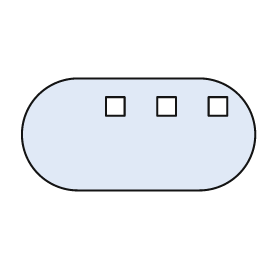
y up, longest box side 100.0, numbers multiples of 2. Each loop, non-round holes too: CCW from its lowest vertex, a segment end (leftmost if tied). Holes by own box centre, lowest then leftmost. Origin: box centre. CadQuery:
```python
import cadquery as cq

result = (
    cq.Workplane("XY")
    .moveTo(-26.0, -24.0)
    .lineTo(26.0, -24.0)
    .threePointArc((50.0, 0.0), (26.0, 24.0))
    .lineTo(-26.0, 24.0)
    .threePointArc((-50.0, 0.0), (-26.0, -24.0))
    .close()
    .moveTo(-14.0, 8.0)
    .lineTo(-6.0, 8.0)
    .lineTo(-6.0, 16.0)
    .lineTo(-14.0, 16.0)
    .close()
    .moveTo(8.0, 8.0)
    .lineTo(16.0, 8.0)
    .lineTo(16.0, 16.0)
    .lineTo(8.0, 16.0)
    .close()
    .moveTo(30.0, 8.0)
    .lineTo(38.0, 8.0)
    .lineTo(38.0, 16.0)
    .lineTo(30.0, 16.0)
    .close()
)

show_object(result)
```